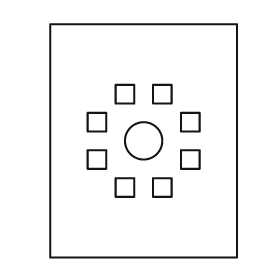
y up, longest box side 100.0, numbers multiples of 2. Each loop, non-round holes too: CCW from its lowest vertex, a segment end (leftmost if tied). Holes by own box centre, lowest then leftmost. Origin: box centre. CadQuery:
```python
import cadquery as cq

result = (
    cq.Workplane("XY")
    .moveTo(-40.0, -50.0)
    .lineTo(40.0, -50.0)
    .lineTo(40.0, 50.0)
    .lineTo(-40.0, 50.0)
    .close()
    .moveTo(-12.0, -24.0)
    .lineTo(-4.0, -24.0)
    .lineTo(-4.0, -16.0)
    .lineTo(-12.0, -16.0)
    .close()
    .moveTo(4.0, -24.0)
    .lineTo(12.0, -24.0)
    .lineTo(12.0, -16.0)
    .lineTo(4.0, -16.0)
    .close()
    .moveTo(-24.0, -12.0)
    .lineTo(-16.0, -12.0)
    .lineTo(-16.0, -4.0)
    .lineTo(-24.0, -4.0)
    .close()
    .moveTo(16.0, -12.0)
    .lineTo(24.0, -12.0)
    .lineTo(24.0, -4.0)
    .lineTo(16.0, -4.0)
    .close()
    .moveTo(0.0, 0.0)
    .circle(8.0)
    .moveTo(-24.0, 4.0)
    .lineTo(-16.0, 4.0)
    .lineTo(-16.0, 12.0)
    .lineTo(-24.0, 12.0)
    .close()
    .moveTo(16.0, 4.0)
    .lineTo(24.0, 4.0)
    .lineTo(24.0, 12.0)
    .lineTo(16.0, 12.0)
    .close()
    .moveTo(-12.0, 16.0)
    .lineTo(-4.0, 16.0)
    .lineTo(-4.0, 24.0)
    .lineTo(-12.0, 24.0)
    .close()
    .moveTo(4.0, 16.0)
    .lineTo(12.0, 16.0)
    .lineTo(12.0, 24.0)
    .lineTo(4.0, 24.0)
    .close()
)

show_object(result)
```